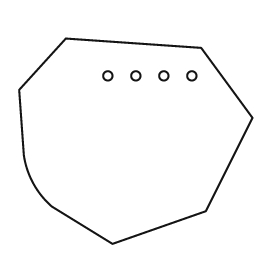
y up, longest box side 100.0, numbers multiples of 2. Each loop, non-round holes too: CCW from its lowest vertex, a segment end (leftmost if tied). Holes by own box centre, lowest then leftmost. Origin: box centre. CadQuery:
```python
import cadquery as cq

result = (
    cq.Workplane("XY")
    .moveTo(-10.0, -44.0)
    .lineTo(30.0, -30.0)
    .lineTo(50.0, 10.0)
    .lineTo(28.0, 40.0)
    .lineTo(-30.0, 44.0)
    .lineTo(-50.0, 22.0)
    .lineTo(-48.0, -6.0)
    .threePointArc((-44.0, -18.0), (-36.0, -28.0))
    .close()
    .moveTo(-12.0, 28.0)
    .circle(2.0)
    .moveTo(0.0, 28.0)
    .circle(2.0)
    .moveTo(12.0, 28.0)
    .circle(2.0)
    .moveTo(24.0, 28.0)
    .circle(2.0)
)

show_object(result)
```